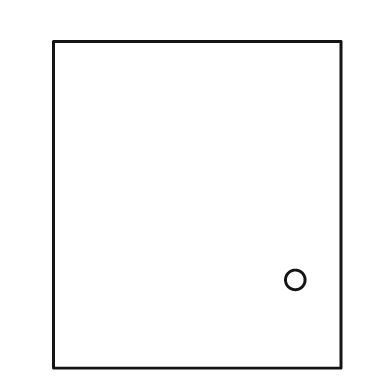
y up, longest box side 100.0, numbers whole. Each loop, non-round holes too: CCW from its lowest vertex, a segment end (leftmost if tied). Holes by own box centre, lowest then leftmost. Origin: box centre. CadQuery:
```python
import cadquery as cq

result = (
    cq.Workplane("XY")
    .moveTo(-44.0, -50.0)
    .lineTo(44.0, -50.0)
    .lineTo(44.0, 50.0)
    .lineTo(-44.0, 50.0)
    .close()
    .moveTo(30.0, -23.0)
    .circle(3.0)
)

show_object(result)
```